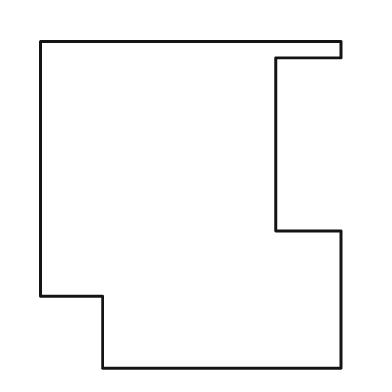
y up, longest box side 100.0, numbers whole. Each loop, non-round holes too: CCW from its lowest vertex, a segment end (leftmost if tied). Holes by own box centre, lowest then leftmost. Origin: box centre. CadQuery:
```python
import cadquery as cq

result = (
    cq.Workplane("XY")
    .moveTo(-27.0, -50.0)
    .lineTo(46.0, -50.0)
    .lineTo(46.0, -8.0)
    .lineTo(26.0, -8.0)
    .lineTo(26.0, 45.0)
    .lineTo(46.0, 45.0)
    .lineTo(46.0, 50.0)
    .lineTo(-46.0, 50.0)
    .lineTo(-46.0, -28.0)
    .lineTo(-27.0, -28.0)
    .close()
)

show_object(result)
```